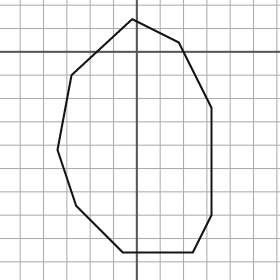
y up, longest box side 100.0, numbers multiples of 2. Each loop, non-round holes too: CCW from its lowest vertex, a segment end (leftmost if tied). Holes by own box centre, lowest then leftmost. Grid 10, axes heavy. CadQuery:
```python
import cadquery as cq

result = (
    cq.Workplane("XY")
    .moveTo(-6.0, -86.0)
    .lineTo(24.0, -86.0)
    .lineTo(32.0, -70.0)
    .lineTo(32.0, -24.0)
    .lineTo(18.0, 4.0)
    .lineTo(-2.0, 14.0)
    .lineTo(-28.0, -10.0)
    .lineTo(-34.0, -42.0)
    .lineTo(-26.0, -66.0)
    .close()
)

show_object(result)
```